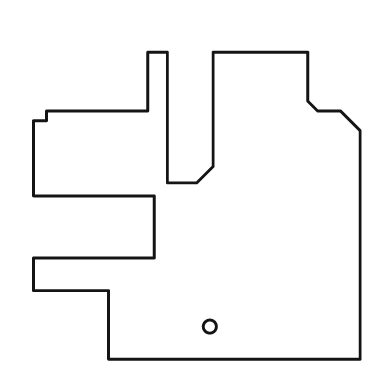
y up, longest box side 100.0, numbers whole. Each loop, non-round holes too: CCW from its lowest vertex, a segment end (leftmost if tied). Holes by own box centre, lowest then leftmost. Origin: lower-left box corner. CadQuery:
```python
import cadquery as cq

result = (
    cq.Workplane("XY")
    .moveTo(23.0, 0.0)
    .lineTo(100.0, 0.0)
    .lineTo(100.0, 70.0)
    .lineTo(94.0, 76.0)
    .lineTo(87.0, 76.0)
    .lineTo(84.0, 79.0)
    .lineTo(84.0, 94.0)
    .lineTo(55.0, 94.0)
    .lineTo(55.0, 59.0)
    .lineTo(50.0, 54.0)
    .lineTo(41.0, 54.0)
    .lineTo(41.0, 94.0)
    .lineTo(35.0, 94.0)
    .lineTo(35.0, 76.0)
    .lineTo(4.0, 76.0)
    .lineTo(4.0, 73.0)
    .lineTo(0.0, 73.0)
    .lineTo(0.0, 50.0)
    .lineTo(37.0, 50.0)
    .lineTo(37.0, 31.0)
    .lineTo(0.0, 31.0)
    .lineTo(0.0, 21.0)
    .lineTo(23.0, 21.0)
    .close()
    .moveTo(54.0, 10.0)
    .circle(2.0)
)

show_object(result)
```